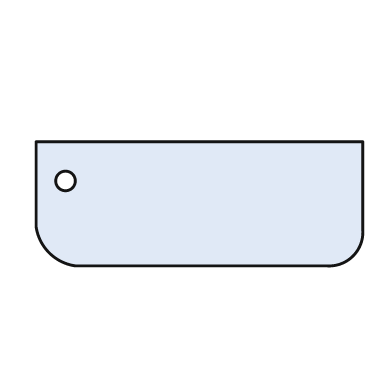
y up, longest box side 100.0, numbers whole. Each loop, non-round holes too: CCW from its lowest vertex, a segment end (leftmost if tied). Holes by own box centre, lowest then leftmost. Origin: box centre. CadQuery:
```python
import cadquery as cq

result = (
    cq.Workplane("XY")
    .moveTo(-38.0, -19.0)
    .lineTo(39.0, -19.0)
    .threePointArc((47.0, -16.0), (50.0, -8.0))
    .lineTo(50.0, 19.0)
    .lineTo(-50.0, 19.0)
    .lineTo(-50.0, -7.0)
    .threePointArc((-46.0, -15.0), (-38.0, -19.0))
    .close()
    .moveTo(-41.0, 7.0)
    .circle(3.0)
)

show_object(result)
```